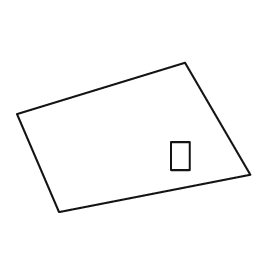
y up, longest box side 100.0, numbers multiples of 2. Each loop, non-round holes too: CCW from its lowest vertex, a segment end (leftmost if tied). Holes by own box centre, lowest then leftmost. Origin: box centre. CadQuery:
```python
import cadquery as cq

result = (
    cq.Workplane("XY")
    .moveTo(-32.0, -32.0)
    .lineTo(50.0, -16.0)
    .lineTo(22.0, 32.0)
    .lineTo(-50.0, 10.0)
    .close()
    .moveTo(16.0, -14.0)
    .lineTo(24.0, -14.0)
    .lineTo(24.0, -2.0)
    .lineTo(16.0, -2.0)
    .close()
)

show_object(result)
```